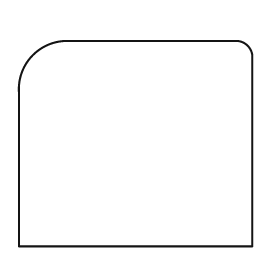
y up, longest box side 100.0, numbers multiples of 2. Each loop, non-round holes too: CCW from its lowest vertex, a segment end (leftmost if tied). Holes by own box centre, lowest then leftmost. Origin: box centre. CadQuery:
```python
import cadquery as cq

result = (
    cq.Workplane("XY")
    .moveTo(-50.0, -44.0)
    .lineTo(50.0, -44.0)
    .lineTo(50.0, 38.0)
    .threePointArc((48.0, 42.0), (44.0, 44.0))
    .lineTo(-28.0, 44.0)
    .threePointArc((-44.0, 38.0), (-50.0, 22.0))
    .close()
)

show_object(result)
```